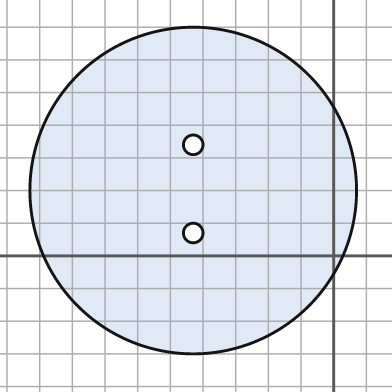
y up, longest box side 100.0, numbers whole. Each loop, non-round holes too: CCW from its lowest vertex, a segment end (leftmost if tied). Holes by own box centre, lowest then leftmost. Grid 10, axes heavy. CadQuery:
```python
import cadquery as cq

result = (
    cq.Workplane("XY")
    .moveTo(-43.0, 20.0)
    .circle(50.0)
    .moveTo(-43.0, 7.0)
    .circle(3.0)
    .moveTo(-43.0, 34.0)
    .circle(3.0)
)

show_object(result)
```